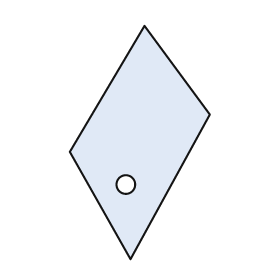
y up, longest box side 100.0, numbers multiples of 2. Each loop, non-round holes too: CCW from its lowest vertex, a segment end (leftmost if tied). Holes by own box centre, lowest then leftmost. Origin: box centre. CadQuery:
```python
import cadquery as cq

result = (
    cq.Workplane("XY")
    .moveTo(-4.0, -50.0)
    .lineTo(30.0, 12.0)
    .lineTo(2.0, 50.0)
    .lineTo(-30.0, -4.0)
    .close()
    .moveTo(-6.0, -18.0)
    .circle(4.0)
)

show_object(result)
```